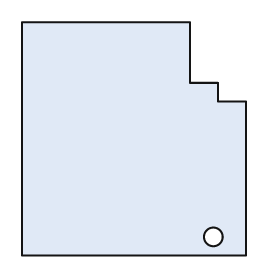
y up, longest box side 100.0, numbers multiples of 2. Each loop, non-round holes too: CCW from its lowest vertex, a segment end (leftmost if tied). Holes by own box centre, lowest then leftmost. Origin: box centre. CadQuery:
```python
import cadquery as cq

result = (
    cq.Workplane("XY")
    .moveTo(-48.0, -50.0)
    .lineTo(48.0, -50.0)
    .lineTo(48.0, 16.0)
    .lineTo(36.0, 16.0)
    .lineTo(36.0, 24.0)
    .lineTo(24.0, 24.0)
    .lineTo(24.0, 50.0)
    .lineTo(-48.0, 50.0)
    .close()
    .moveTo(34.0, -42.0)
    .circle(4.0)
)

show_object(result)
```